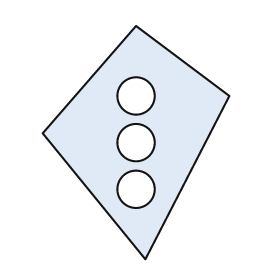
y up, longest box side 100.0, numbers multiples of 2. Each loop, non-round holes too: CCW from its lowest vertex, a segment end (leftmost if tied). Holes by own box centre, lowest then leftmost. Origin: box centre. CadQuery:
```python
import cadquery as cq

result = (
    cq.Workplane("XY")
    .moveTo(4.0, -50.0)
    .lineTo(40.0, 20.0)
    .lineTo(0.0, 50.0)
    .lineTo(-40.0, 4.0)
    .close()
    .moveTo(0.0, -20.0)
    .circle(8.0)
    .moveTo(0.0, 0.0)
    .circle(8.0)
    .moveTo(0.0, 20.0)
    .circle(8.0)
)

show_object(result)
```